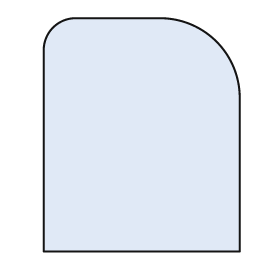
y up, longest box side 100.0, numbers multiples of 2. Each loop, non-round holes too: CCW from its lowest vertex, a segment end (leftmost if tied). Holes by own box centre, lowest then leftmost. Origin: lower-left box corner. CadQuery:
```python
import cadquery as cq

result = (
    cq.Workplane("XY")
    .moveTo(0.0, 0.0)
    .lineTo(84.0, 0.0)
    .lineTo(84.0, 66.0)
    .threePointArc((74.0, 90.0), (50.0, 100.0))
    .lineTo(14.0, 100.0)
    .threePointArc((4.0, 96.0), (0.0, 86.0))
    .close()
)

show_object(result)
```